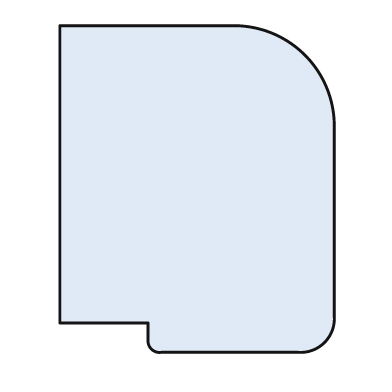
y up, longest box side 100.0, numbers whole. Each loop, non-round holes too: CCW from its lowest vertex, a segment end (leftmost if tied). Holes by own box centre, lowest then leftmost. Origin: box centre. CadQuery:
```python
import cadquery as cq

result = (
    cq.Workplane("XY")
    .moveTo(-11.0, -50.0)
    .lineTo(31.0, -50.0)
    .threePointArc((39.0, -47.0), (42.0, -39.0))
    .lineTo(42.0, 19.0)
    .threePointArc((33.0, 41.0), (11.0, 50.0))
    .lineTo(-42.0, 50.0)
    .lineTo(-42.0, -41.0)
    .lineTo(-15.0, -41.0)
    .lineTo(-15.0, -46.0)
    .threePointArc((-14.0, -49.0), (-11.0, -50.0))
    .close()
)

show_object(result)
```